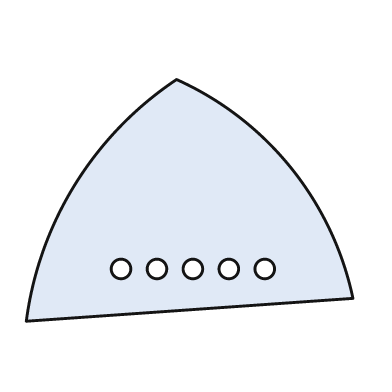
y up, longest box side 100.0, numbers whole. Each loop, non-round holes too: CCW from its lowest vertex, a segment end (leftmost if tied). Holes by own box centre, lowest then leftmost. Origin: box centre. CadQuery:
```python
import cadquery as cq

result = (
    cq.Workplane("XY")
    .moveTo(-50.0, -37.0)
    .lineTo(50.0, -30.0)
    .threePointArc((31.0, 10.0), (-4.0, 37.0))
    .threePointArc((-35.0, 5.0), (-50.0, -37.0))
    .close()
    .moveTo(-21.0, -21.0)
    .circle(3.0)
    .moveTo(-10.0, -21.0)
    .circle(3.0)
    .moveTo(1.0, -21.0)
    .circle(3.0)
    .moveTo(12.0, -21.0)
    .circle(3.0)
    .moveTo(23.0, -21.0)
    .circle(3.0)
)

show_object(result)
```